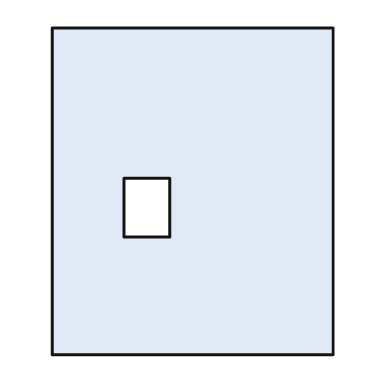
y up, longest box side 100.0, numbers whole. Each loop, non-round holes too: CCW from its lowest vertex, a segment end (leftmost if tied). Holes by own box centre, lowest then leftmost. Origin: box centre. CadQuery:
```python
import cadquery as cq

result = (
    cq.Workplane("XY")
    .moveTo(-43.0, -50.0)
    .lineTo(43.0, -50.0)
    .lineTo(43.0, 50.0)
    .lineTo(-43.0, 50.0)
    .close()
    .moveTo(-21.0, -14.0)
    .lineTo(-7.0, -14.0)
    .lineTo(-7.0, 4.0)
    .lineTo(-21.0, 4.0)
    .close()
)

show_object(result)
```